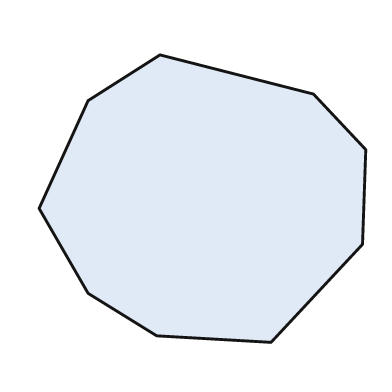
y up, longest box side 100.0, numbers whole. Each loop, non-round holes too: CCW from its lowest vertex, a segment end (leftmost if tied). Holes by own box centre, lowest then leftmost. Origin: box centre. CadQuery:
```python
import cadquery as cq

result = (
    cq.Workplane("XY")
    .moveTo(21.0, -44.0)
    .lineTo(49.0, -14.0)
    .lineTo(50.0, 15.0)
    .lineTo(34.0, 32.0)
    .lineTo(-13.0, 44.0)
    .lineTo(-35.0, 30.0)
    .lineTo(-50.0, -3.0)
    .lineTo(-35.0, -29.0)
    .lineTo(-14.0, -42.0)
    .close()
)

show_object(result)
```